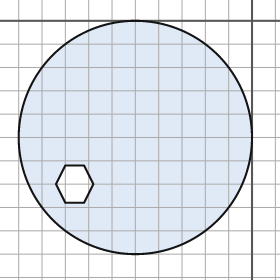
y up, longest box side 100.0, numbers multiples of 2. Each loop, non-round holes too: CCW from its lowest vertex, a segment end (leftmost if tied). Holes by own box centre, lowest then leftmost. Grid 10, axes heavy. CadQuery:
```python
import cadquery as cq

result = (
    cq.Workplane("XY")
    .moveTo(-50.0, -50.0)
    .circle(50.0)
    .moveTo(-80.0, -78.0)
    .lineTo(-72.0, -78.0)
    .lineTo(-68.0, -70.0)
    .lineTo(-72.0, -62.0)
    .lineTo(-80.0, -62.0)
    .lineTo(-84.0, -70.0)
    .close()
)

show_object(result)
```